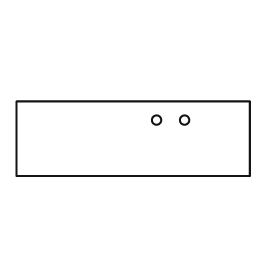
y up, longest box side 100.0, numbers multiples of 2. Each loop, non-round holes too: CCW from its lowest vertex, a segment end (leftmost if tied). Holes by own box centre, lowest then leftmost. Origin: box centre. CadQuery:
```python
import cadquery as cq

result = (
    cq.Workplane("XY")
    .moveTo(-50.0, -16.0)
    .lineTo(50.0, -16.0)
    .lineTo(50.0, 16.0)
    .lineTo(-50.0, 16.0)
    .close()
    .moveTo(10.0, 8.0)
    .circle(2.0)
    .moveTo(22.0, 8.0)
    .circle(2.0)
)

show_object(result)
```